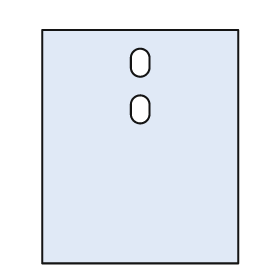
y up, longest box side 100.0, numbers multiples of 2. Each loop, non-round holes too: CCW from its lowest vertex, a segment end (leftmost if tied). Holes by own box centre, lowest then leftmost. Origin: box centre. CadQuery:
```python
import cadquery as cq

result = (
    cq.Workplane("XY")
    .moveTo(-42.0, -50.0)
    .lineTo(42.0, -50.0)
    .lineTo(42.0, 50.0)
    .lineTo(-42.0, 50.0)
    .close()
    .moveTo(-4.0, 14.0)
    .threePointArc((0.0, 10.0), (4.0, 14.0))
    .lineTo(4.0, 18.0)
    .threePointArc((0.0, 22.0), (-4.0, 18.0))
    .close()
    .moveTo(-4.0, 34.0)
    .threePointArc((0.0, 30.0), (4.0, 34.0))
    .lineTo(4.0, 38.0)
    .threePointArc((0.0, 42.0), (-4.0, 38.0))
    .close()
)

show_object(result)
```